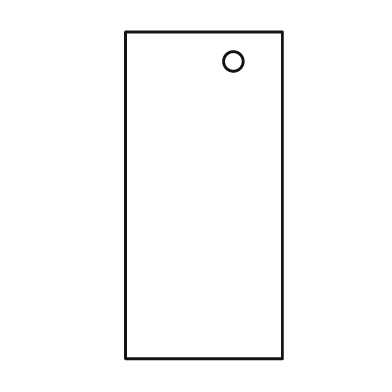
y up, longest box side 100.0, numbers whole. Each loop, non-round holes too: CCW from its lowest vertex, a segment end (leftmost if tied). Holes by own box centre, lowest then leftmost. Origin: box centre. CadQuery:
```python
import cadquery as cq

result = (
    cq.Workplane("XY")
    .moveTo(-24.0, -50.0)
    .lineTo(24.0, -50.0)
    .lineTo(24.0, 50.0)
    .lineTo(-24.0, 50.0)
    .close()
    .moveTo(9.0, 41.0)
    .circle(3.0)
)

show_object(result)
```